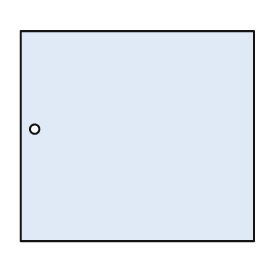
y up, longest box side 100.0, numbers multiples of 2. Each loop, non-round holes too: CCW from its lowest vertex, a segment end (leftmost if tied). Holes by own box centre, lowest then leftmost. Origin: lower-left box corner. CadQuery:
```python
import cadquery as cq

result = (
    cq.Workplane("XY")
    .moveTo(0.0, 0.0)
    .lineTo(100.0, 0.0)
    .lineTo(100.0, 90.0)
    .lineTo(0.0, 90.0)
    .close()
    .moveTo(6.0, 48.0)
    .circle(2.0)
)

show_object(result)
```